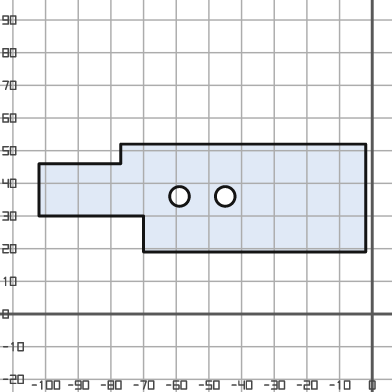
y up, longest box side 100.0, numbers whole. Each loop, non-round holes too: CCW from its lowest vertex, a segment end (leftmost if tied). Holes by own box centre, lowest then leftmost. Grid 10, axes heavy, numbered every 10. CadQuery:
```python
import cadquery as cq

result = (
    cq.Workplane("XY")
    .moveTo(-70.0, 19.0)
    .lineTo(-2.0, 19.0)
    .lineTo(-2.0, 52.0)
    .lineTo(-77.0, 52.0)
    .lineTo(-77.0, 46.0)
    .lineTo(-102.0, 46.0)
    .lineTo(-102.0, 30.0)
    .lineTo(-70.0, 30.0)
    .close()
    .moveTo(-59.0, 36.0)
    .circle(3.0)
    .moveTo(-45.0, 36.0)
    .circle(3.0)
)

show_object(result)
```